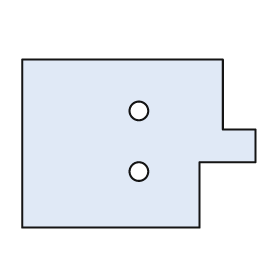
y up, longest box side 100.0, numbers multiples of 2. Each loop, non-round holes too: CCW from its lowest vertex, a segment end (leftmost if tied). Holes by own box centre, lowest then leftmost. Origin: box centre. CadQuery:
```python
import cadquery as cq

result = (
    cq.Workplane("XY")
    .moveTo(-50.0, -36.0)
    .lineTo(26.0, -36.0)
    .lineTo(26.0, -8.0)
    .lineTo(50.0, -8.0)
    .lineTo(50.0, 6.0)
    .lineTo(36.0, 6.0)
    .lineTo(36.0, 36.0)
    .lineTo(-50.0, 36.0)
    .close()
    .moveTo(0.0, -12.0)
    .circle(4.0)
    .moveTo(0.0, 14.0)
    .circle(4.0)
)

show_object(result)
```